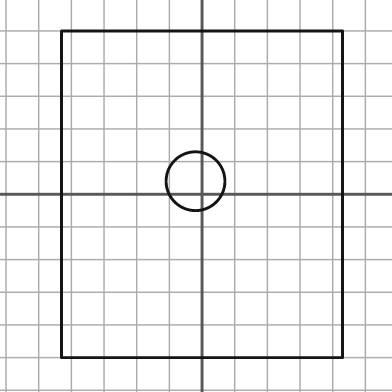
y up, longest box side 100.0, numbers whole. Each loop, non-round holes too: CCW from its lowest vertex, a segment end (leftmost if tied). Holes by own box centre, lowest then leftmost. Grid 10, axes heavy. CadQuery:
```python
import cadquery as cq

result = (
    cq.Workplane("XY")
    .moveTo(-43.0, -50.0)
    .lineTo(43.0, -50.0)
    .lineTo(43.0, 50.0)
    .lineTo(-43.0, 50.0)
    .close()
    .moveTo(-2.0, 4.0)
    .circle(9.0)
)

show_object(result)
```